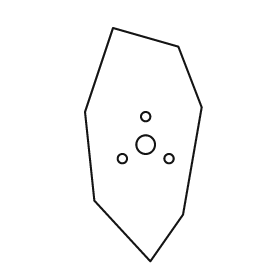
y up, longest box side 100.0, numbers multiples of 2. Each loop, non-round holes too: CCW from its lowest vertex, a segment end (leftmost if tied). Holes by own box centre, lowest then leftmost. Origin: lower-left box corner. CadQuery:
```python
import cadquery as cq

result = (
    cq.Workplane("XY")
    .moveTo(28.0, 0.0)
    .lineTo(42.0, 20.0)
    .lineTo(50.0, 66.0)
    .lineTo(40.0, 92.0)
    .lineTo(12.0, 100.0)
    .lineTo(0.0, 64.0)
    .lineTo(4.0, 26.0)
    .close()
    .moveTo(16.0, 44.0)
    .circle(2.0)
    .moveTo(36.0, 44.0)
    .circle(2.0)
    .moveTo(26.0, 50.0)
    .circle(4.0)
    .moveTo(26.0, 62.0)
    .circle(2.0)
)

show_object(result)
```